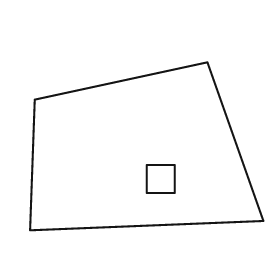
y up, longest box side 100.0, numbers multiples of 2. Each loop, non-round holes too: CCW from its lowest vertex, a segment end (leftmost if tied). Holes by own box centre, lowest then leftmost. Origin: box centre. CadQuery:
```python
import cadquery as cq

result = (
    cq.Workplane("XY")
    .moveTo(-50.0, -36.0)
    .lineTo(50.0, -32.0)
    .lineTo(26.0, 36.0)
    .lineTo(-48.0, 20.0)
    .close()
    .moveTo(0.0, -20.0)
    .lineTo(12.0, -20.0)
    .lineTo(12.0, -8.0)
    .lineTo(0.0, -8.0)
    .close()
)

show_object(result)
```